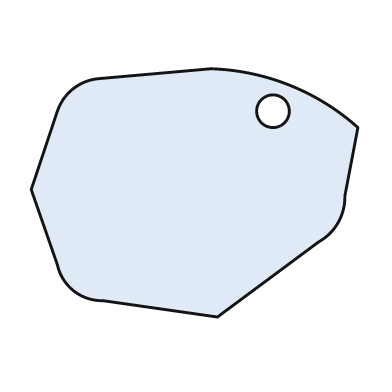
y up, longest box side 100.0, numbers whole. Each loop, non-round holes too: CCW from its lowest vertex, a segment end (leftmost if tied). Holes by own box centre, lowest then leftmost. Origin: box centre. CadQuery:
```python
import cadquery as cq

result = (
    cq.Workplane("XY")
    .moveTo(7.0, -38.0)
    .lineTo(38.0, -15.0)
    .threePointArc((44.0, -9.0), (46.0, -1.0))
    .lineTo(50.0, 20.0)
    .threePointArc((29.0, 33.0), (5.0, 38.0))
    .lineTo(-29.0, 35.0)
    .threePointArc((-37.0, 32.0), (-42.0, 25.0))
    .lineTo(-50.0, 1.0)
    .lineTo(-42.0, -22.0)
    .threePointArc((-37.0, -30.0), (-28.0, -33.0))
    .close()
    .moveTo(24.0, 25.0)
    .circle(5.0)
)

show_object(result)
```